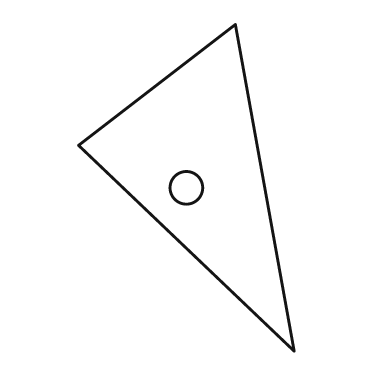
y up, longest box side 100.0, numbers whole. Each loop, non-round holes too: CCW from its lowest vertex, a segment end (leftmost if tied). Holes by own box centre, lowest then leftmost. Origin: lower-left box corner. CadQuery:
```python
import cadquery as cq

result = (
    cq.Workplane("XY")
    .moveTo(66.0, 0.0)
    .lineTo(48.0, 100.0)
    .lineTo(0.0, 63.0)
    .close()
    .moveTo(33.0, 50.0)
    .circle(5.0)
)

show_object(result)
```